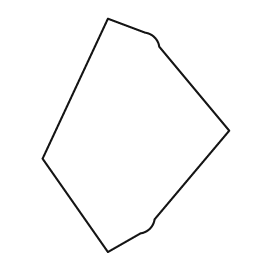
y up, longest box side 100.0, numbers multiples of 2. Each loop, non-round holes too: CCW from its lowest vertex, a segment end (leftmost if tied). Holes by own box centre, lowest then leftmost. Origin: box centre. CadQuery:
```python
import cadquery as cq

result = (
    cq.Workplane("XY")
    .moveTo(-12.0, -50.0)
    .lineTo(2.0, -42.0)
    .threePointArc((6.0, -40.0), (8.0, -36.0))
    .lineTo(40.0, 2.0)
    .lineTo(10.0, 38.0)
    .threePointArc((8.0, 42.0), (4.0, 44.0))
    .lineTo(-12.0, 50.0)
    .lineTo(-40.0, -10.0)
    .close()
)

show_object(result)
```